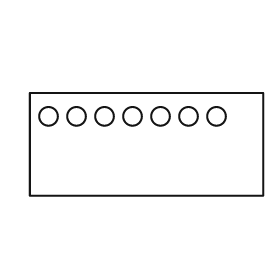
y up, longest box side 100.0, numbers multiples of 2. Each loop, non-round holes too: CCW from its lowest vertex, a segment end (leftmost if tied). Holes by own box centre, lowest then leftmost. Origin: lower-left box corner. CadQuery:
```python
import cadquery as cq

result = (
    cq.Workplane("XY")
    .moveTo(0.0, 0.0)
    .lineTo(100.0, 0.0)
    .lineTo(100.0, 44.0)
    .lineTo(0.0, 44.0)
    .close()
    .moveTo(8.0, 34.0)
    .circle(4.0)
    .moveTo(20.0, 34.0)
    .circle(4.0)
    .moveTo(32.0, 34.0)
    .circle(4.0)
    .moveTo(44.0, 34.0)
    .circle(4.0)
    .moveTo(56.0, 34.0)
    .circle(4.0)
    .moveTo(68.0, 34.0)
    .circle(4.0)
    .moveTo(80.0, 34.0)
    .circle(4.0)
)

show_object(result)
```